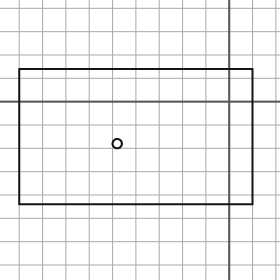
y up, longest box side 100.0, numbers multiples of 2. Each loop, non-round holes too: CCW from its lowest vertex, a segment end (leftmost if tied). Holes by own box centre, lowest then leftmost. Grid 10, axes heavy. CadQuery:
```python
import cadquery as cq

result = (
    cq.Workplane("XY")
    .moveTo(-90.0, -44.0)
    .lineTo(10.0, -44.0)
    .lineTo(10.0, 14.0)
    .lineTo(-90.0, 14.0)
    .close()
    .moveTo(-48.0, -18.0)
    .circle(2.0)
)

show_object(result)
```